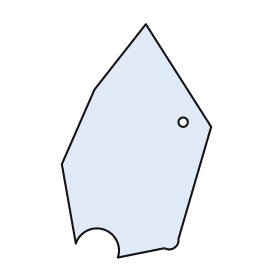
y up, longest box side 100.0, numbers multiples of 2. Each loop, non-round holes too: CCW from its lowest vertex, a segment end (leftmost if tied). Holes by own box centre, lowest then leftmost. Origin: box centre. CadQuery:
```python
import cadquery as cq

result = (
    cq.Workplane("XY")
    .moveTo(-8.0, -50.0)
    .lineTo(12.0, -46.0)
    .threePointArc((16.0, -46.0), (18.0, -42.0))
    .lineTo(32.0, 6.0)
    .lineTo(4.0, 50.0)
    .lineTo(-18.0, 22.0)
    .lineTo(-32.0, -10.0)
    .lineTo(-26.0, -44.0)
    .threePointArc((-14.0, -38.0), (-8.0, -50.0))
    .close()
    .moveTo(20.0, 8.0)
    .circle(2.0)
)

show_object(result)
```